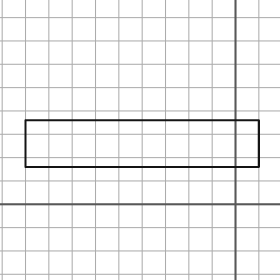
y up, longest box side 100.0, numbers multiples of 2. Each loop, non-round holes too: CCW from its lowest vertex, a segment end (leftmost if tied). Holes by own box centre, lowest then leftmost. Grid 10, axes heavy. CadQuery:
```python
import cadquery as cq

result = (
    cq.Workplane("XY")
    .moveTo(-90.0, 16.0)
    .lineTo(10.0, 16.0)
    .lineTo(10.0, 36.0)
    .lineTo(-90.0, 36.0)
    .close()
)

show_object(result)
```